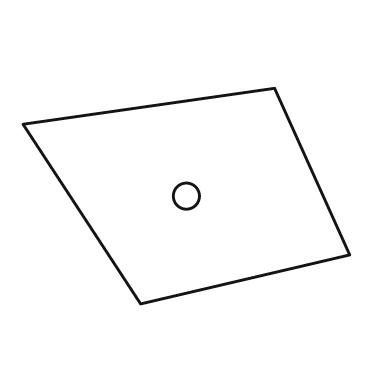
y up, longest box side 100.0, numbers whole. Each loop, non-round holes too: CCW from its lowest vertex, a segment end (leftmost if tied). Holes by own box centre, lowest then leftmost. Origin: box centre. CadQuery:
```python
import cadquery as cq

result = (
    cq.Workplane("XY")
    .moveTo(-14.0, -33.0)
    .lineTo(50.0, -18.0)
    .lineTo(27.0, 33.0)
    .lineTo(-50.0, 22.0)
    .close()
    .moveTo(0.0, 0.0)
    .circle(4.0)
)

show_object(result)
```